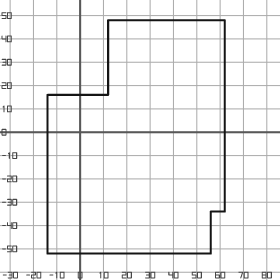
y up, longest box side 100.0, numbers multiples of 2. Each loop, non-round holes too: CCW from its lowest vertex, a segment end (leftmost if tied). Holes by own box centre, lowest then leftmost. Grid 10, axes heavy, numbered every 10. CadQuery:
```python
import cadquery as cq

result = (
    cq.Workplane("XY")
    .moveTo(-14.0, -52.0)
    .lineTo(56.0, -52.0)
    .lineTo(56.0, -34.0)
    .lineTo(62.0, -34.0)
    .lineTo(62.0, 48.0)
    .lineTo(12.0, 48.0)
    .lineTo(12.0, 16.0)
    .lineTo(-14.0, 16.0)
    .close()
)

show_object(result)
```